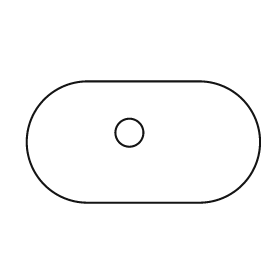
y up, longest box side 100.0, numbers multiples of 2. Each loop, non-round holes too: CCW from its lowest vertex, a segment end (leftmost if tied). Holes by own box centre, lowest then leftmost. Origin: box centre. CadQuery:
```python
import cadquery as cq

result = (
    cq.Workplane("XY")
    .moveTo(-24.0, -26.0)
    .lineTo(24.0, -26.0)
    .threePointArc((50.0, 0.0), (24.0, 26.0))
    .lineTo(-24.0, 26.0)
    .threePointArc((-50.0, 0.0), (-24.0, -26.0))
    .close()
    .moveTo(-6.0, 4.0)
    .circle(6.0)
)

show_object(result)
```